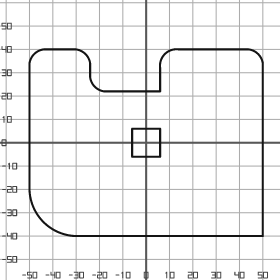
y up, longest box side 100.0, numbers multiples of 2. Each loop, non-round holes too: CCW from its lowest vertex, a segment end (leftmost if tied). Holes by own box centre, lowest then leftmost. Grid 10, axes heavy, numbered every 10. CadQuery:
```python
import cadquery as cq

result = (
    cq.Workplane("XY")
    .moveTo(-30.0, -40.0)
    .lineTo(50.0, -40.0)
    .lineTo(50.0, 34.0)
    .threePointArc((48.0, 38.0), (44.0, 40.0))
    .lineTo(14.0, 40.0)
    .threePointArc((8.0, 38.0), (6.0, 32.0))
    .lineTo(6.0, 22.0)
    .lineTo(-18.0, 22.0)
    .threePointArc((-22.0, 24.0), (-24.0, 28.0))
    .lineTo(-24.0, 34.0)
    .threePointArc((-26.0, 38.0), (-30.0, 40.0))
    .lineTo(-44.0, 40.0)
    .threePointArc((-48.0, 38.0), (-50.0, 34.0))
    .lineTo(-50.0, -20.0)
    .threePointArc((-44.0, -34.0), (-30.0, -40.0))
    .close()
    .moveTo(-6.0, -6.0)
    .lineTo(6.0, -6.0)
    .lineTo(6.0, 6.0)
    .lineTo(-6.0, 6.0)
    .close()
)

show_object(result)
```